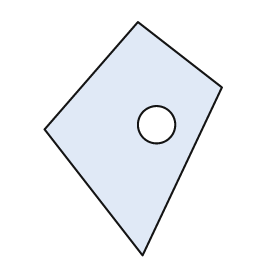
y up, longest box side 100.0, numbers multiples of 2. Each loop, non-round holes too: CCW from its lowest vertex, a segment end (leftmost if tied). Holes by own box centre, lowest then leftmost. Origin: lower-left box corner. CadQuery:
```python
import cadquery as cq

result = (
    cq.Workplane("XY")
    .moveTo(42.0, 0.0)
    .lineTo(76.0, 72.0)
    .lineTo(40.0, 100.0)
    .lineTo(0.0, 54.0)
    .close()
    .moveTo(48.0, 56.0)
    .circle(8.0)
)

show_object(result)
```